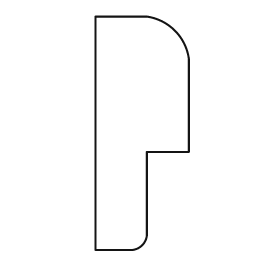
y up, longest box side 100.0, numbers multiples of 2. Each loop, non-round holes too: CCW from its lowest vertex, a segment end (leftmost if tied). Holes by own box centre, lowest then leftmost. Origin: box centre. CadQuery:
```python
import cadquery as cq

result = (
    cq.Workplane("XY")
    .moveTo(-20.0, -50.0)
    .lineTo(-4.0, -50.0)
    .threePointArc((0.0, -48.0), (2.0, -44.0))
    .lineTo(2.0, -8.0)
    .lineTo(20.0, -8.0)
    .lineTo(20.0, 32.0)
    .threePointArc((14.0, 44.0), (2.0, 50.0))
    .lineTo(-20.0, 50.0)
    .close()
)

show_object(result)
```